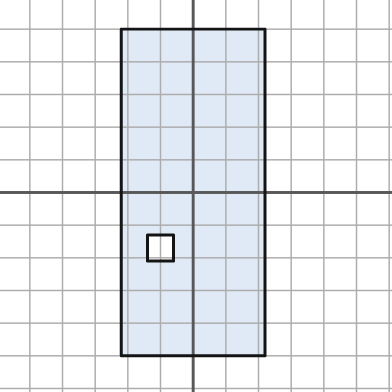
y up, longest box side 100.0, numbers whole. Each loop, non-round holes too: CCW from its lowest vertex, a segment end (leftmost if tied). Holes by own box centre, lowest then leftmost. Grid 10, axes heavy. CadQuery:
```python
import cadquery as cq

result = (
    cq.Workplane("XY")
    .moveTo(-22.0, -50.0)
    .lineTo(22.0, -50.0)
    .lineTo(22.0, 50.0)
    .lineTo(-22.0, 50.0)
    .close()
    .moveTo(-14.0, -21.0)
    .lineTo(-6.0, -21.0)
    .lineTo(-6.0, -13.0)
    .lineTo(-14.0, -13.0)
    .close()
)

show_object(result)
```